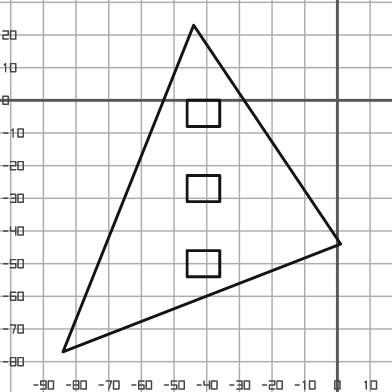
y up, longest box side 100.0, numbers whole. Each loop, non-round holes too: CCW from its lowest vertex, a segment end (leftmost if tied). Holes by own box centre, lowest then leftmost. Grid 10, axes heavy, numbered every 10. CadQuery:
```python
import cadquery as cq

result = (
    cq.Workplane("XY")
    .moveTo(-84.0, -77.0)
    .lineTo(1.0, -44.0)
    .lineTo(-44.0, 23.0)
    .close()
    .moveTo(-46.0, -54.0)
    .lineTo(-36.0, -54.0)
    .lineTo(-36.0, -46.0)
    .lineTo(-46.0, -46.0)
    .close()
    .moveTo(-46.0, -31.0)
    .lineTo(-36.0, -31.0)
    .lineTo(-36.0, -23.0)
    .lineTo(-46.0, -23.0)
    .close()
    .moveTo(-46.0, -8.0)
    .lineTo(-36.0, -8.0)
    .lineTo(-36.0, 0.0)
    .lineTo(-46.0, 0.0)
    .close()
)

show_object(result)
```